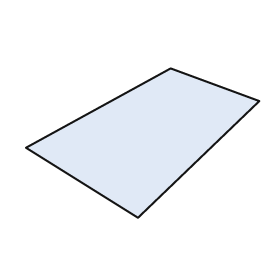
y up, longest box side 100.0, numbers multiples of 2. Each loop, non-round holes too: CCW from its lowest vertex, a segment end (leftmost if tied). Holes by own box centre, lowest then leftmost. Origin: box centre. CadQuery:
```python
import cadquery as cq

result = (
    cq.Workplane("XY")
    .moveTo(-2.0, -32.0)
    .lineTo(50.0, 18.0)
    .lineTo(12.0, 32.0)
    .lineTo(-50.0, -2.0)
    .close()
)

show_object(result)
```